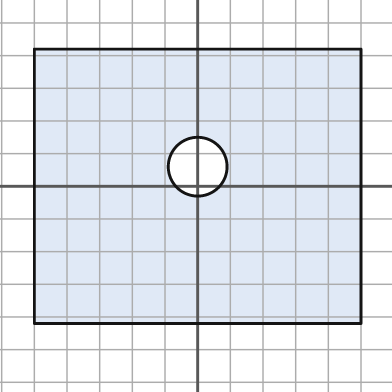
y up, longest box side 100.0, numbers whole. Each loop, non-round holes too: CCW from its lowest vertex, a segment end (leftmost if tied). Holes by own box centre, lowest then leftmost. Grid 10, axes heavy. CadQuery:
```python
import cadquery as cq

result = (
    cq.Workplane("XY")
    .moveTo(-50.0, -42.0)
    .lineTo(50.0, -42.0)
    .lineTo(50.0, 42.0)
    .lineTo(-50.0, 42.0)
    .close()
    .moveTo(0.0, 6.0)
    .circle(9.0)
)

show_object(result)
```